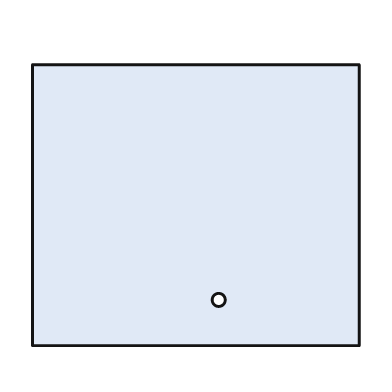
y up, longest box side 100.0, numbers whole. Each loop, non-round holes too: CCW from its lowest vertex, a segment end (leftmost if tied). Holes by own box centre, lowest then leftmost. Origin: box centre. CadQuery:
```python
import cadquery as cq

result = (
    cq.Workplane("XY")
    .moveTo(-50.0, -43.0)
    .lineTo(50.0, -43.0)
    .lineTo(50.0, 43.0)
    .lineTo(-50.0, 43.0)
    .close()
    .moveTo(7.0, -29.0)
    .circle(2.0)
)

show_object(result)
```